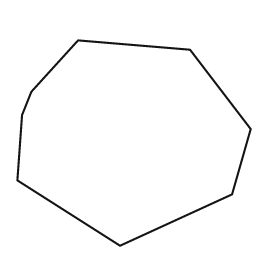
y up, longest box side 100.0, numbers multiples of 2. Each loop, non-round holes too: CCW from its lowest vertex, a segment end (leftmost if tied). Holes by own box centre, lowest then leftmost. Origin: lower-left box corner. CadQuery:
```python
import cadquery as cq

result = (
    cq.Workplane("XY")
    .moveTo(44.0, 0.0)
    .lineTo(92.0, 22.0)
    .lineTo(100.0, 50.0)
    .lineTo(74.0, 84.0)
    .lineTo(26.0, 88.0)
    .lineTo(6.0, 66.0)
    .lineTo(2.0, 56.0)
    .lineTo(0.0, 28.0)
    .close()
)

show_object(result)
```